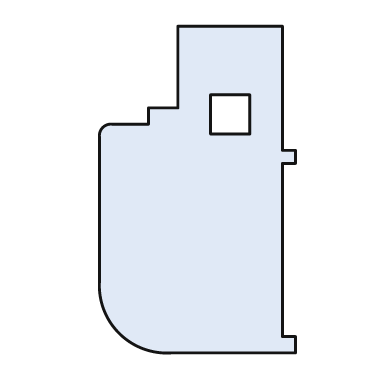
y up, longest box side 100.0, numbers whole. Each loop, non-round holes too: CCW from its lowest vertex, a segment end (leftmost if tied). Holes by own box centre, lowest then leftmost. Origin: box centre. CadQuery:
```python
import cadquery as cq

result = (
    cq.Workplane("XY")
    .moveTo(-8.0, -50.0)
    .lineTo(30.0, -50.0)
    .lineTo(30.0, -45.0)
    .lineTo(26.0, -45.0)
    .lineTo(26.0, 8.0)
    .lineTo(30.0, 8.0)
    .lineTo(30.0, 12.0)
    .lineTo(26.0, 12.0)
    .lineTo(26.0, 50.0)
    .lineTo(-6.0, 50.0)
    .lineTo(-6.0, 25.0)
    .lineTo(-15.0, 25.0)
    .lineTo(-15.0, 20.0)
    .lineTo(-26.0, 20.0)
    .threePointArc((-29.0, 19.0), (-30.0, 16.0))
    .lineTo(-30.0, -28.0)
    .threePointArc((-24.0, -44.0), (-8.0, -50.0))
    .close()
    .moveTo(4.0, 17.0)
    .lineTo(16.0, 17.0)
    .lineTo(16.0, 29.0)
    .lineTo(4.0, 29.0)
    .close()
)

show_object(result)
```